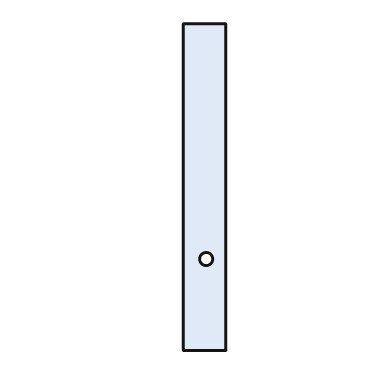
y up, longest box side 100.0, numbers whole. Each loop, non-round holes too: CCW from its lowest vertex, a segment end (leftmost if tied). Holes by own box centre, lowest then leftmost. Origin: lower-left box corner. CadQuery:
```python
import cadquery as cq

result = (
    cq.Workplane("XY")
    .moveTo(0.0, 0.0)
    .lineTo(13.0, 0.0)
    .lineTo(13.0, 100.0)
    .lineTo(0.0, 100.0)
    .close()
    .moveTo(7.0, 28.0)
    .circle(2.0)
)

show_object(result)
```